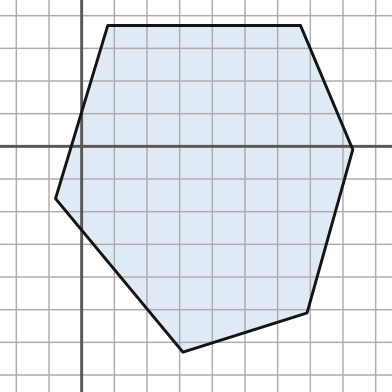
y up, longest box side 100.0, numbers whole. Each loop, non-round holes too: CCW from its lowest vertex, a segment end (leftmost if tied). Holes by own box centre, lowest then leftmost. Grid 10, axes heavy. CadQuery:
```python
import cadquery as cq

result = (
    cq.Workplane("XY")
    .moveTo(31.0, -63.0)
    .lineTo(69.0, -51.0)
    .lineTo(83.0, -1.0)
    .lineTo(67.0, 37.0)
    .lineTo(8.0, 37.0)
    .lineTo(-8.0, -16.0)
    .close()
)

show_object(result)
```